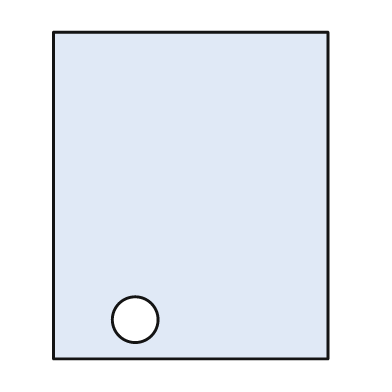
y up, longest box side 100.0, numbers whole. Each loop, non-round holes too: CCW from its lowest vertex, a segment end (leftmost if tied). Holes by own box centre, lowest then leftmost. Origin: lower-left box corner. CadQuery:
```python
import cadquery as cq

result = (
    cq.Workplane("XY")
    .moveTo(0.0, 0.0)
    .lineTo(84.0, 0.0)
    .lineTo(84.0, 100.0)
    .lineTo(0.0, 100.0)
    .close()
    .moveTo(25.0, 12.0)
    .circle(7.0)
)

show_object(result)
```